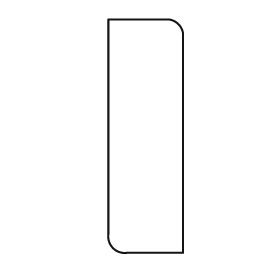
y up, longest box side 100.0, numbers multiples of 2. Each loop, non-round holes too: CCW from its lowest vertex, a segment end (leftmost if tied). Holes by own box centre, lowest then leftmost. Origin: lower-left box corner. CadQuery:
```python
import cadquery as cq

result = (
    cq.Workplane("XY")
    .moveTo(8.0, 0.0)
    .lineTo(32.0, 0.0)
    .lineTo(32.0, 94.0)
    .threePointArc((30.0, 98.0), (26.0, 100.0))
    .lineTo(0.0, 100.0)
    .lineTo(0.0, 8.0)
    .threePointArc((2.0, 2.0), (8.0, 0.0))
    .close()
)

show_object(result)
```